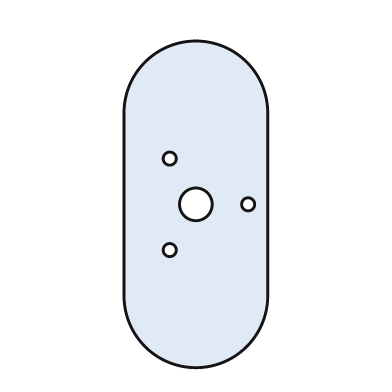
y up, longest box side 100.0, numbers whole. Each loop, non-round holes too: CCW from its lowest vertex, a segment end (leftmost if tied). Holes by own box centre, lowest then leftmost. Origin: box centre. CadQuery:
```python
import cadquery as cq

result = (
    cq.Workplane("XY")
    .moveTo(-22.0, -28.0)
    .threePointArc((0.0, -50.0), (22.0, -28.0))
    .lineTo(22.0, 28.0)
    .threePointArc((0.0, 50.0), (-22.0, 28.0))
    .close()
    .moveTo(-8.0, -14.0)
    .circle(2.0)
    .moveTo(0.0, 0.0)
    .circle(5.0)
    .moveTo(16.0, 0.0)
    .circle(2.0)
    .moveTo(-8.0, 14.0)
    .circle(2.0)
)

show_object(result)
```